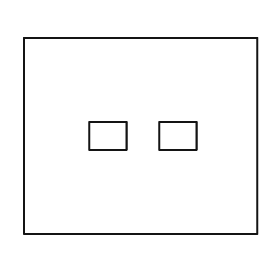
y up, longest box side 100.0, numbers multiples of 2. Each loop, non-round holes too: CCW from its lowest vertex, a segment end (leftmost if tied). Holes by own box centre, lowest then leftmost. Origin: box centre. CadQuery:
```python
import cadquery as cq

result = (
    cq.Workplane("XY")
    .moveTo(-50.0, -42.0)
    .lineTo(50.0, -42.0)
    .lineTo(50.0, 42.0)
    .lineTo(-50.0, 42.0)
    .close()
    .moveTo(-22.0, -6.0)
    .lineTo(-6.0, -6.0)
    .lineTo(-6.0, 6.0)
    .lineTo(-22.0, 6.0)
    .close()
    .moveTo(8.0, -6.0)
    .lineTo(24.0, -6.0)
    .lineTo(24.0, 6.0)
    .lineTo(8.0, 6.0)
    .close()
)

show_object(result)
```